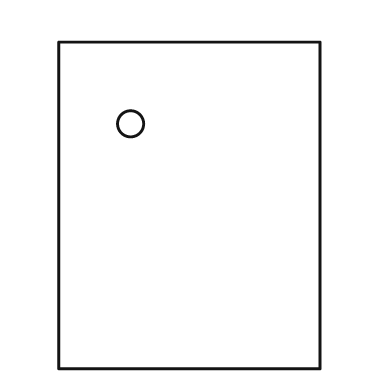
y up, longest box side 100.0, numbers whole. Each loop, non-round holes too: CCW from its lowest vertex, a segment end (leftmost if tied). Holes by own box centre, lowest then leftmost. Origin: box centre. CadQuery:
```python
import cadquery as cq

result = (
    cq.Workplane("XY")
    .moveTo(-40.0, -50.0)
    .lineTo(40.0, -50.0)
    .lineTo(40.0, 50.0)
    .lineTo(-40.0, 50.0)
    .close()
    .moveTo(-18.0, 25.0)
    .circle(4.0)
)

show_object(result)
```